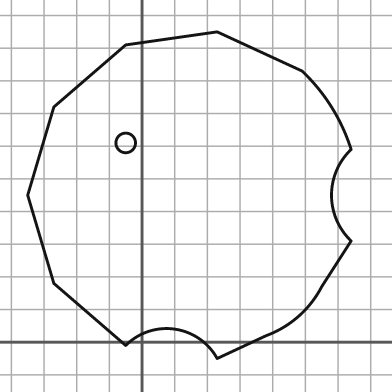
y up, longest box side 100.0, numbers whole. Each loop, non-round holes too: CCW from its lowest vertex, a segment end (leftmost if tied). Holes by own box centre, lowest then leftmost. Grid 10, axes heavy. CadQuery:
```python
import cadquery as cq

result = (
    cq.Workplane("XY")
    .moveTo(23.0, -5.0)
    .lineTo(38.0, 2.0)
    .threePointArc((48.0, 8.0), (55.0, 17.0))
    .lineTo(64.0, 31.0)
    .threePointArc((58.0, 45.0), (64.0, 59.0))
    .threePointArc((58.0, 72.0), (49.0, 83.0))
    .lineTo(23.0, 95.0)
    .lineTo(-5.0, 91.0)
    .lineTo(-27.0, 72.0)
    .lineTo(-35.0, 45.0)
    .lineTo(-27.0, 18.0)
    .lineTo(-5.0, -1.0)
    .threePointArc((10.0, 4.0), (23.0, -5.0))
    .close()
    .moveTo(-5.0, 61.0)
    .circle(3.0)
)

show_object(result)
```